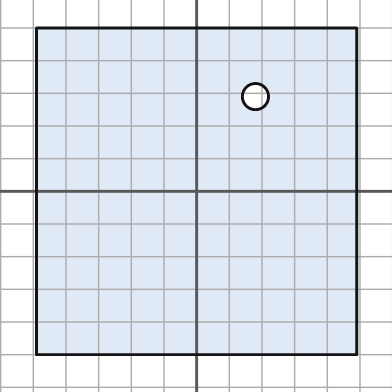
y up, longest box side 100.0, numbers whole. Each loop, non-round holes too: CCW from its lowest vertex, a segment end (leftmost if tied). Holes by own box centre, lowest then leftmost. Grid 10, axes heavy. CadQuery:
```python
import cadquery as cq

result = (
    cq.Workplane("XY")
    .moveTo(-49.0, -50.0)
    .lineTo(49.0, -50.0)
    .lineTo(49.0, 50.0)
    .lineTo(-49.0, 50.0)
    .close()
    .moveTo(18.0, 29.0)
    .circle(4.0)
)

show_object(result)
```